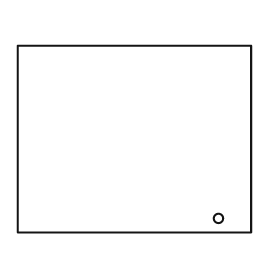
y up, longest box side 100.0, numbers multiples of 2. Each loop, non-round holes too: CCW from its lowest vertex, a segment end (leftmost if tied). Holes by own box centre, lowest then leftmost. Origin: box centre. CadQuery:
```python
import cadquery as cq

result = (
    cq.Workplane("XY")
    .moveTo(-50.0, -40.0)
    .lineTo(50.0, -40.0)
    .lineTo(50.0, 40.0)
    .lineTo(-50.0, 40.0)
    .close()
    .moveTo(36.0, -34.0)
    .circle(2.0)
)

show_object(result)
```